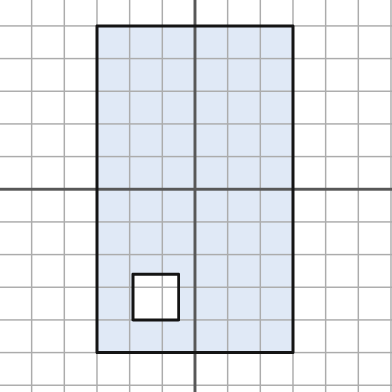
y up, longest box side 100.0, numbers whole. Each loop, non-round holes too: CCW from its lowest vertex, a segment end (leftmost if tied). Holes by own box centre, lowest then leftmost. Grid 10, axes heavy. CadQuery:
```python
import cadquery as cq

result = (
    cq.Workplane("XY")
    .moveTo(-30.0, -50.0)
    .lineTo(30.0, -50.0)
    .lineTo(30.0, 50.0)
    .lineTo(-30.0, 50.0)
    .close()
    .moveTo(-19.0, -40.0)
    .lineTo(-5.0, -40.0)
    .lineTo(-5.0, -26.0)
    .lineTo(-19.0, -26.0)
    .close()
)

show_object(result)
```